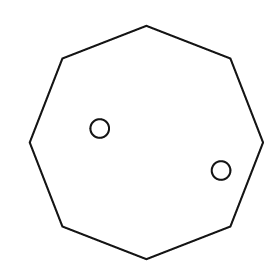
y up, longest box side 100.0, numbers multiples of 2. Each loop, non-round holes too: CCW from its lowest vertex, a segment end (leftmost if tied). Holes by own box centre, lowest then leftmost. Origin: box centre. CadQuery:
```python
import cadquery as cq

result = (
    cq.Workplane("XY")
    .moveTo(0.0, -50.0)
    .lineTo(36.0, -36.0)
    .lineTo(50.0, 0.0)
    .lineTo(36.0, 36.0)
    .lineTo(0.0, 50.0)
    .lineTo(-36.0, 36.0)
    .lineTo(-50.0, 0.0)
    .lineTo(-36.0, -36.0)
    .close()
    .moveTo(32.0, -12.0)
    .circle(4.0)
    .moveTo(-20.0, 6.0)
    .circle(4.0)
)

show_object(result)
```